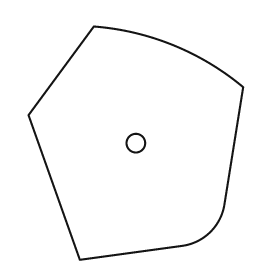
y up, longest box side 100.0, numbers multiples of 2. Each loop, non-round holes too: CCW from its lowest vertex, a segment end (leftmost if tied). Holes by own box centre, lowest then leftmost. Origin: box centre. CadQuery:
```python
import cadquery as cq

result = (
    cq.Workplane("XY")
    .moveTo(-24.0, -50.0)
    .lineTo(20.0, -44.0)
    .threePointArc((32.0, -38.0), (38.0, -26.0))
    .lineTo(46.0, 24.0)
    .threePointArc((16.0, 42.0), (-18.0, 50.0))
    .lineTo(-46.0, 12.0)
    .close()
    .moveTo(0.0, 0.0)
    .circle(4.0)
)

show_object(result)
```